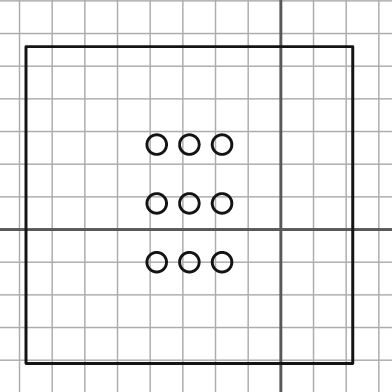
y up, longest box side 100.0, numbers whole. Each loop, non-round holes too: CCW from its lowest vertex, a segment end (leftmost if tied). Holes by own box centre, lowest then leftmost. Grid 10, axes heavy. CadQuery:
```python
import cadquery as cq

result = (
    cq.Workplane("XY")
    .moveTo(-78.0, -41.0)
    .lineTo(22.0, -41.0)
    .lineTo(22.0, 56.0)
    .lineTo(-78.0, 56.0)
    .close()
    .moveTo(-38.0, -10.0)
    .circle(3.0)
    .moveTo(-28.0, -10.0)
    .circle(3.0)
    .moveTo(-18.0, -10.0)
    .circle(3.0)
    .moveTo(-38.0, 8.0)
    .circle(3.0)
    .moveTo(-28.0, 8.0)
    .circle(3.0)
    .moveTo(-18.0, 8.0)
    .circle(3.0)
    .moveTo(-38.0, 26.0)
    .circle(3.0)
    .moveTo(-28.0, 26.0)
    .circle(3.0)
    .moveTo(-18.0, 26.0)
    .circle(3.0)
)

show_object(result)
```